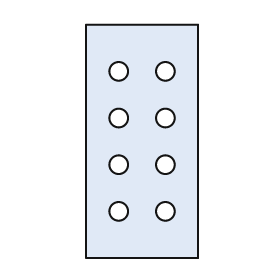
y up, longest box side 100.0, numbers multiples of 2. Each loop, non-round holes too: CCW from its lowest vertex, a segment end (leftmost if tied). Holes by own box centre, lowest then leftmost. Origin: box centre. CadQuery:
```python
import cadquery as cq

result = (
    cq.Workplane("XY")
    .moveTo(-24.0, -50.0)
    .lineTo(24.0, -50.0)
    .lineTo(24.0, 50.0)
    .lineTo(-24.0, 50.0)
    .close()
    .moveTo(-10.0, -30.0)
    .circle(4.0)
    .moveTo(10.0, -30.0)
    .circle(4.0)
    .moveTo(-10.0, -10.0)
    .circle(4.0)
    .moveTo(10.0, -10.0)
    .circle(4.0)
    .moveTo(-10.0, 10.0)
    .circle(4.0)
    .moveTo(10.0, 10.0)
    .circle(4.0)
    .moveTo(-10.0, 30.0)
    .circle(4.0)
    .moveTo(10.0, 30.0)
    .circle(4.0)
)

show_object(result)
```